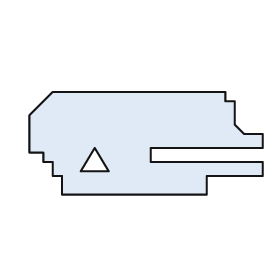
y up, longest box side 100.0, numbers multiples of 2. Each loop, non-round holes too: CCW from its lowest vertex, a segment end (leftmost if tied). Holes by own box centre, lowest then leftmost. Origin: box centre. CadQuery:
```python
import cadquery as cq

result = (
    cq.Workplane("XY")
    .moveTo(-36.0, -22.0)
    .lineTo(26.0, -22.0)
    .lineTo(26.0, -14.0)
    .lineTo(50.0, -14.0)
    .lineTo(50.0, -8.0)
    .lineTo(2.0, -8.0)
    .lineTo(2.0, -2.0)
    .lineTo(50.0, -2.0)
    .lineTo(50.0, 4.0)
    .lineTo(42.0, 4.0)
    .lineTo(38.0, 8.0)
    .lineTo(38.0, 18.0)
    .lineTo(34.0, 18.0)
    .lineTo(34.0, 22.0)
    .lineTo(-40.0, 22.0)
    .lineTo(-50.0, 12.0)
    .lineTo(-50.0, -4.0)
    .lineTo(-44.0, -4.0)
    .lineTo(-44.0, -8.0)
    .lineTo(-40.0, -8.0)
    .lineTo(-40.0, -14.0)
    .lineTo(-36.0, -14.0)
    .close()
    .moveTo(-28.0, -12.0)
    .lineTo(-16.0, -12.0)
    .lineTo(-22.0, -2.0)
    .close()
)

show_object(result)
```